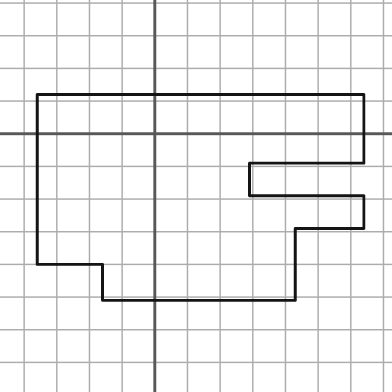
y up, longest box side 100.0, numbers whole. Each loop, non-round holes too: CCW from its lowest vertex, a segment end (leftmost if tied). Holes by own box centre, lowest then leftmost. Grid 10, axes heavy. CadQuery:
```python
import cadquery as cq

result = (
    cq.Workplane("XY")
    .moveTo(-16.0, -51.0)
    .lineTo(43.0, -51.0)
    .lineTo(43.0, -29.0)
    .lineTo(64.0, -29.0)
    .lineTo(64.0, -19.0)
    .lineTo(29.0, -19.0)
    .lineTo(29.0, -9.0)
    .lineTo(64.0, -9.0)
    .lineTo(64.0, 12.0)
    .lineTo(-36.0, 12.0)
    .lineTo(-36.0, -40.0)
    .lineTo(-16.0, -40.0)
    .close()
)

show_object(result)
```